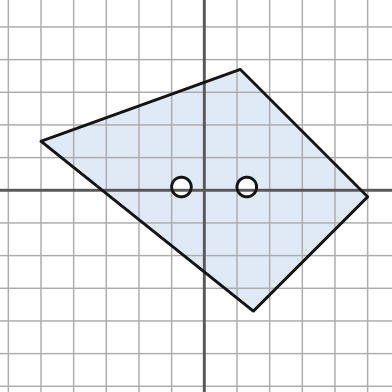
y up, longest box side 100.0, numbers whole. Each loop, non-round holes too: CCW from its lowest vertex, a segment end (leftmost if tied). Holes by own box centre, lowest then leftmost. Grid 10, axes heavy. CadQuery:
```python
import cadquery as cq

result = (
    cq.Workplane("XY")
    .moveTo(15.0, -37.0)
    .lineTo(50.0, -2.0)
    .lineTo(11.0, 37.0)
    .lineTo(-50.0, 15.0)
    .close()
    .moveTo(-7.0, 1.0)
    .circle(3.0)
    .moveTo(13.0, 1.0)
    .circle(3.0)
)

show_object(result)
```